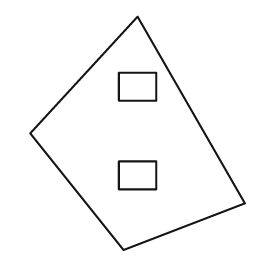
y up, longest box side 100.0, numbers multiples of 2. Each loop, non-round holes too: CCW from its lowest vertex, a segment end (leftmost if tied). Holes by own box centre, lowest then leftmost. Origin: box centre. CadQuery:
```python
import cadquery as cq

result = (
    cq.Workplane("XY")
    .moveTo(-6.0, -50.0)
    .lineTo(46.0, -30.0)
    .lineTo(0.0, 50.0)
    .lineTo(-46.0, 0.0)
    .close()
    .moveTo(-8.0, -24.0)
    .lineTo(8.0, -24.0)
    .lineTo(8.0, -12.0)
    .lineTo(-8.0, -12.0)
    .close()
    .moveTo(-8.0, 14.0)
    .lineTo(8.0, 14.0)
    .lineTo(8.0, 26.0)
    .lineTo(-8.0, 26.0)
    .close()
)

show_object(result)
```